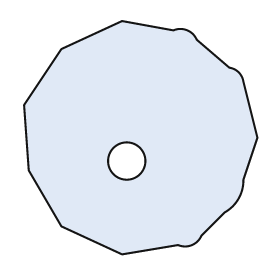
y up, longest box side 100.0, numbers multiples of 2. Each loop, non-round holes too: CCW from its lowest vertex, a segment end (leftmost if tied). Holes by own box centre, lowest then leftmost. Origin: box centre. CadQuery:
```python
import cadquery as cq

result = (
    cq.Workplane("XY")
    .moveTo(-8.0, -50.0)
    .lineTo(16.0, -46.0)
    .threePointArc((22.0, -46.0), (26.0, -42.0))
    .lineTo(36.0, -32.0)
    .threePointArc((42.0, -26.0), (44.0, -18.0))
    .lineTo(50.0, 0.0)
    .lineTo(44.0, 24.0)
    .threePointArc((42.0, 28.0), (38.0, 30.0))
    .lineTo(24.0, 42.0)
    .threePointArc((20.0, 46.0), (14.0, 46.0))
    .lineTo(-8.0, 50.0)
    .lineTo(-34.0, 38.0)
    .lineTo(-50.0, 14.0)
    .lineTo(-48.0, -14.0)
    .lineTo(-34.0, -38.0)
    .close()
    .moveTo(-6.0, -10.0)
    .circle(8.0)
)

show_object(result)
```